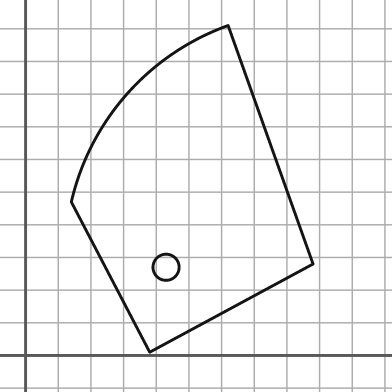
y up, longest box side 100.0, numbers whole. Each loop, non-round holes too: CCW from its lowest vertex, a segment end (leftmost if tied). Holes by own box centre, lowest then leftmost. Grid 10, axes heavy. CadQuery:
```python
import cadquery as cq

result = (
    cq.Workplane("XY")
    .moveTo(38.0, 1.0)
    .lineTo(88.0, 28.0)
    .lineTo(62.0, 101.0)
    .threePointArc((31.0, 80.0), (14.0, 47.0))
    .close()
    .moveTo(43.0, 27.0)
    .circle(4.0)
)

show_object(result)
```